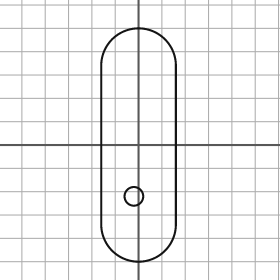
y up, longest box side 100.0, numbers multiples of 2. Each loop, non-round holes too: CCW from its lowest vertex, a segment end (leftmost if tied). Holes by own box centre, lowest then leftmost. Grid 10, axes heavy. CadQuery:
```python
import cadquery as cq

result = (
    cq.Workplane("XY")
    .moveTo(-16.0, -34.0)
    .threePointArc((0.0, -50.0), (16.0, -34.0))
    .lineTo(16.0, 34.0)
    .threePointArc((0.0, 50.0), (-16.0, 34.0))
    .close()
    .moveTo(-2.0, -22.0)
    .circle(4.0)
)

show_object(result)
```